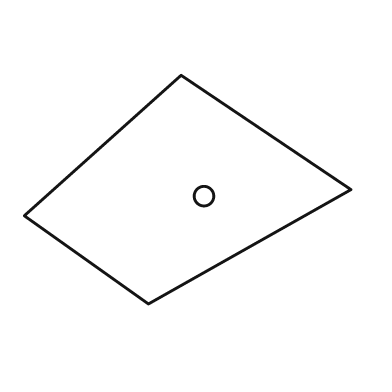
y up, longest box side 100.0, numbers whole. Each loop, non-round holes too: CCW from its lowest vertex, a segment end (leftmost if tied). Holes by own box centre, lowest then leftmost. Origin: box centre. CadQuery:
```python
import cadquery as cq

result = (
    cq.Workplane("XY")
    .moveTo(-12.0, -35.0)
    .lineTo(50.0, 0.0)
    .lineTo(-2.0, 35.0)
    .lineTo(-50.0, -8.0)
    .close()
    .moveTo(5.0, -2.0)
    .circle(3.0)
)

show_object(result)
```